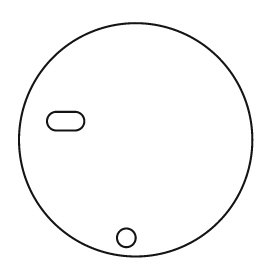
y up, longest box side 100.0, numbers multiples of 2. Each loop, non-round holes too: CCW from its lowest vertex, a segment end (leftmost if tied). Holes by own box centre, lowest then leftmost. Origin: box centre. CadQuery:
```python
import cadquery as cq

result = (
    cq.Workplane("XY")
    .moveTo(0.0, 0.0)
    .circle(50.0)
    .moveTo(-4.0, -42.0)
    .circle(4.0)
    .moveTo(-34.0, 4.0)
    .lineTo(-26.0, 4.0)
    .threePointArc((-22.0, 8.0), (-26.0, 12.0))
    .lineTo(-34.0, 12.0)
    .threePointArc((-38.0, 8.0), (-34.0, 4.0))
    .close()
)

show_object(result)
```